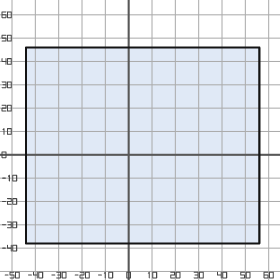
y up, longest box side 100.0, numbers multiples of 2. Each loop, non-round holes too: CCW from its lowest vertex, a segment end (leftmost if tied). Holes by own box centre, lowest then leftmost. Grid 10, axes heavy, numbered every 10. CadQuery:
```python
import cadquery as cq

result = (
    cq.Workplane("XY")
    .moveTo(-44.0, -38.0)
    .lineTo(56.0, -38.0)
    .lineTo(56.0, 46.0)
    .lineTo(-44.0, 46.0)
    .close()
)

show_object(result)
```